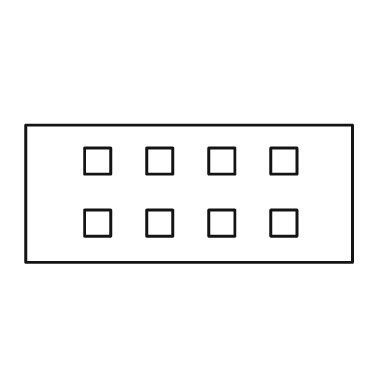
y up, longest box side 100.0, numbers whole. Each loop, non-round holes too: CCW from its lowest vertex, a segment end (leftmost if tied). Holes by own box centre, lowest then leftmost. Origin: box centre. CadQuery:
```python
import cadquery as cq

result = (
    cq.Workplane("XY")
    .moveTo(-50.0, -21.0)
    .lineTo(50.0, -21.0)
    .lineTo(50.0, 21.0)
    .lineTo(-50.0, 21.0)
    .close()
    .moveTo(-32.0, -13.0)
    .lineTo(-24.0, -13.0)
    .lineTo(-24.0, -5.0)
    .lineTo(-32.0, -5.0)
    .close()
    .moveTo(-13.0, -13.0)
    .lineTo(-5.0, -13.0)
    .lineTo(-5.0, -5.0)
    .lineTo(-13.0, -5.0)
    .close()
    .moveTo(6.0, -13.0)
    .lineTo(14.0, -13.0)
    .lineTo(14.0, -5.0)
    .lineTo(6.0, -5.0)
    .close()
    .moveTo(25.0, -13.0)
    .lineTo(33.0, -13.0)
    .lineTo(33.0, -5.0)
    .lineTo(25.0, -5.0)
    .close()
    .moveTo(-32.0, 6.0)
    .lineTo(-24.0, 6.0)
    .lineTo(-24.0, 14.0)
    .lineTo(-32.0, 14.0)
    .close()
    .moveTo(-13.0, 6.0)
    .lineTo(-5.0, 6.0)
    .lineTo(-5.0, 14.0)
    .lineTo(-13.0, 14.0)
    .close()
    .moveTo(6.0, 6.0)
    .lineTo(14.0, 6.0)
    .lineTo(14.0, 14.0)
    .lineTo(6.0, 14.0)
    .close()
    .moveTo(25.0, 6.0)
    .lineTo(33.0, 6.0)
    .lineTo(33.0, 14.0)
    .lineTo(25.0, 14.0)
    .close()
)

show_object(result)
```